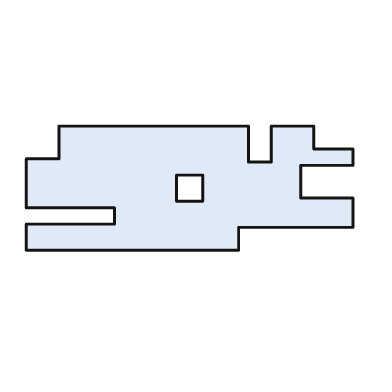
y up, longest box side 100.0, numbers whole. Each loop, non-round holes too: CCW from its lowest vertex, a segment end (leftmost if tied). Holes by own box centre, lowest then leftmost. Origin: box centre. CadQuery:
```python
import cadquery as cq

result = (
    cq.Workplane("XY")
    .moveTo(-50.0, -19.0)
    .lineTo(15.0, -19.0)
    .lineTo(15.0, -12.0)
    .lineTo(50.0, -12.0)
    .lineTo(50.0, -3.0)
    .lineTo(34.0, -3.0)
    .lineTo(34.0, 7.0)
    .lineTo(50.0, 7.0)
    .lineTo(50.0, 12.0)
    .lineTo(38.0, 12.0)
    .lineTo(38.0, 19.0)
    .lineTo(25.0, 19.0)
    .lineTo(25.0, 8.0)
    .lineTo(18.0, 8.0)
    .lineTo(18.0, 19.0)
    .lineTo(-40.0, 19.0)
    .lineTo(-40.0, 9.0)
    .lineTo(-50.0, 9.0)
    .lineTo(-50.0, -6.0)
    .lineTo(-23.0, -6.0)
    .lineTo(-23.0, -11.0)
    .lineTo(-50.0, -11.0)
    .close()
    .moveTo(-4.0, -4.0)
    .lineTo(4.0, -4.0)
    .lineTo(4.0, 4.0)
    .lineTo(-4.0, 4.0)
    .close()
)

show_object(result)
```